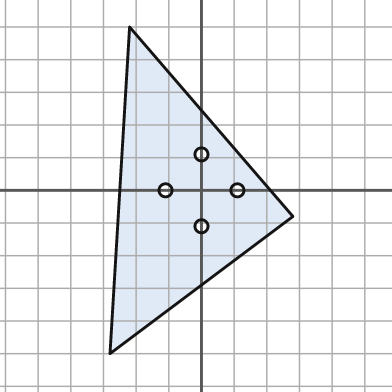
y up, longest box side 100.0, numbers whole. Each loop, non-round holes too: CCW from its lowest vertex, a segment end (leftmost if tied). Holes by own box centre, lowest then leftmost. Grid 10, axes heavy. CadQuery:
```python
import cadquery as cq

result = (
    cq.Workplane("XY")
    .moveTo(-28.0, -50.0)
    .lineTo(28.0, -8.0)
    .lineTo(-22.0, 50.0)
    .close()
    .moveTo(0.0, -11.0)
    .circle(2.0)
    .moveTo(-11.0, 0.0)
    .circle(2.0)
    .moveTo(11.0, 0.0)
    .circle(2.0)
    .moveTo(0.0, 11.0)
    .circle(2.0)
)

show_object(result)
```